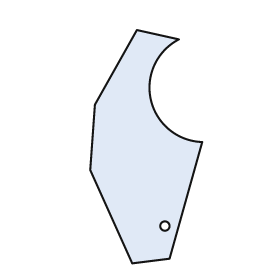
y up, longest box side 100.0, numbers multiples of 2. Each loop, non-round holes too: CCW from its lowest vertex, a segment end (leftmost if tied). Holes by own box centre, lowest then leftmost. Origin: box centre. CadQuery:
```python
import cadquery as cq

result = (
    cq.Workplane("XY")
    .moveTo(-6.0, -50.0)
    .lineTo(10.0, -48.0)
    .lineTo(24.0, 2.0)
    .threePointArc((2.0, 20.0), (14.0, 46.0))
    .lineTo(-4.0, 50.0)
    .lineTo(-22.0, 18.0)
    .lineTo(-24.0, -10.0)
    .close()
    .moveTo(8.0, -34.0)
    .circle(2.0)
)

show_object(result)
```